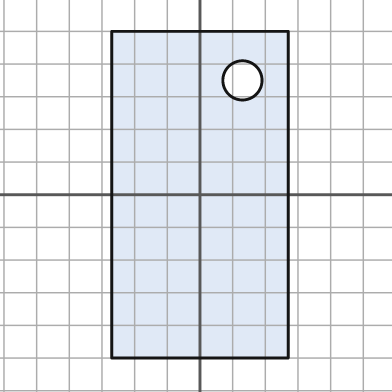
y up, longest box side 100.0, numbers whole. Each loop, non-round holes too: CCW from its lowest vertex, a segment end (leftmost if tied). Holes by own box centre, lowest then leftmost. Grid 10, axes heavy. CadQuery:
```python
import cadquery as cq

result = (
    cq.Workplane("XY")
    .moveTo(-27.0, -50.0)
    .lineTo(27.0, -50.0)
    .lineTo(27.0, 50.0)
    .lineTo(-27.0, 50.0)
    .close()
    .moveTo(13.0, 35.0)
    .circle(6.0)
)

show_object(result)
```